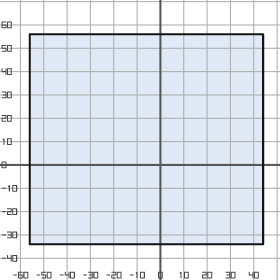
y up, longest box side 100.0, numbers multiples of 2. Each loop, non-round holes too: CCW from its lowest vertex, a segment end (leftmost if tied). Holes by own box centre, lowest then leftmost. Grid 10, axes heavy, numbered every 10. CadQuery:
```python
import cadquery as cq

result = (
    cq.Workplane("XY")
    .moveTo(-56.0, -34.0)
    .lineTo(44.0, -34.0)
    .lineTo(44.0, 56.0)
    .lineTo(-56.0, 56.0)
    .close()
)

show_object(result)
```